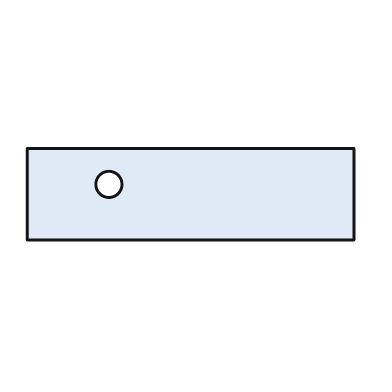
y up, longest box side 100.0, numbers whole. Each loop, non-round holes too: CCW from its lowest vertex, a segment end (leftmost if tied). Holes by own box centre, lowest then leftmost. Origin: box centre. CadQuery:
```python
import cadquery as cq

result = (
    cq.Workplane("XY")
    .moveTo(-50.0, -14.0)
    .lineTo(50.0, -14.0)
    .lineTo(50.0, 14.0)
    .lineTo(-50.0, 14.0)
    .close()
    .moveTo(-25.0, 3.0)
    .circle(4.0)
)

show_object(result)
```